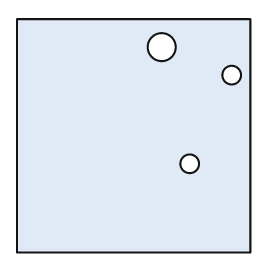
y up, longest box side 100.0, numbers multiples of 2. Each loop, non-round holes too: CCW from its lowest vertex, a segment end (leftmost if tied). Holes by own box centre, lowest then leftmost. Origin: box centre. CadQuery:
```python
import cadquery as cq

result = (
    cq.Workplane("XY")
    .moveTo(-50.0, -50.0)
    .lineTo(50.0, -50.0)
    .lineTo(50.0, 50.0)
    .lineTo(-50.0, 50.0)
    .close()
    .moveTo(24.0, -12.0)
    .circle(4.0)
    .moveTo(42.0, 26.0)
    .circle(4.0)
    .moveTo(12.0, 38.0)
    .circle(6.0)
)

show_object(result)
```